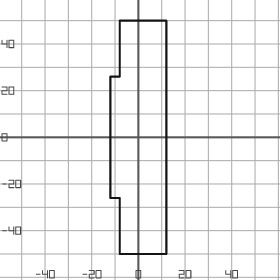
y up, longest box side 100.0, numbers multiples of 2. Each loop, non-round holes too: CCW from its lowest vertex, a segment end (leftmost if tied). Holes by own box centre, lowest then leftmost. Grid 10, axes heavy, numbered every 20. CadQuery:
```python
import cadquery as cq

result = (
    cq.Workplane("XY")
    .moveTo(-8.0, -50.0)
    .lineTo(12.0, -50.0)
    .lineTo(12.0, 50.0)
    .lineTo(-8.0, 50.0)
    .lineTo(-8.0, 26.0)
    .lineTo(-12.0, 26.0)
    .lineTo(-12.0, -26.0)
    .lineTo(-8.0, -26.0)
    .close()
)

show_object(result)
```